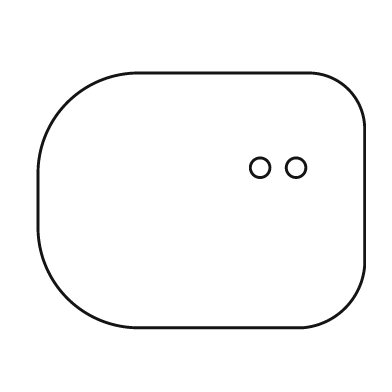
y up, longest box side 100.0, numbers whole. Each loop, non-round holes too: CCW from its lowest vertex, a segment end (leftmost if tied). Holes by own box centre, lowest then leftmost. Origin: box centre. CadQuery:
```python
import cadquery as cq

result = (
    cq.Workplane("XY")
    .moveTo(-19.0, -39.0)
    .lineTo(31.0, -39.0)
    .threePointArc((44.0, -33.0), (50.0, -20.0))
    .lineTo(50.0, 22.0)
    .threePointArc((45.0, 34.0), (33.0, 39.0))
    .lineTo(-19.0, 39.0)
    .threePointArc((-41.0, 30.0), (-50.0, 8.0))
    .lineTo(-50.0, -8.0)
    .threePointArc((-41.0, -30.0), (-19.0, -39.0))
    .close()
    .moveTo(18.0, 10.0)
    .circle(3.0)
    .moveTo(29.0, 10.0)
    .circle(3.0)
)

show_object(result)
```